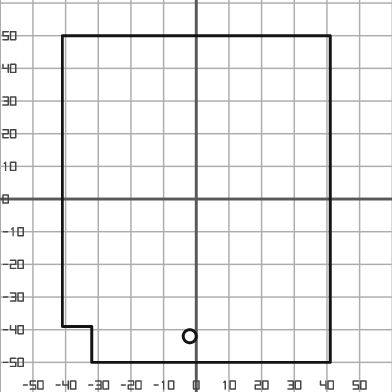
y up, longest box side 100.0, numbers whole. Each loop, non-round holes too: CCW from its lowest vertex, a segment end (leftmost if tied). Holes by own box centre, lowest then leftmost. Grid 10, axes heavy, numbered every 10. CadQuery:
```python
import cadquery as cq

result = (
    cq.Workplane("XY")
    .moveTo(-32.0, -50.0)
    .lineTo(41.0, -50.0)
    .lineTo(41.0, 50.0)
    .lineTo(-41.0, 50.0)
    .lineTo(-41.0, -39.0)
    .lineTo(-32.0, -39.0)
    .close()
    .moveTo(-2.0, -42.0)
    .circle(2.0)
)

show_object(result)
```